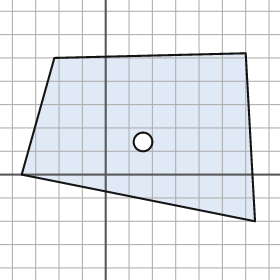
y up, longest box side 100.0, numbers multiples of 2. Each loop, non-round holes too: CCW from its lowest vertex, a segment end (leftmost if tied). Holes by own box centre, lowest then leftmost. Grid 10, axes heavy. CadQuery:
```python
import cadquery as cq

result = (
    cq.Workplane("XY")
    .moveTo(64.0, -20.0)
    .lineTo(60.0, 52.0)
    .lineTo(-22.0, 50.0)
    .lineTo(-36.0, 0.0)
    .close()
    .moveTo(16.0, 14.0)
    .circle(4.0)
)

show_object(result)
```